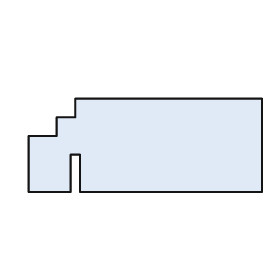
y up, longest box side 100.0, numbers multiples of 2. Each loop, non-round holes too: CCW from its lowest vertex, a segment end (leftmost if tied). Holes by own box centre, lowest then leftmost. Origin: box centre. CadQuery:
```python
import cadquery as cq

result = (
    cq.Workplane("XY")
    .moveTo(-50.0, -20.0)
    .lineTo(-32.0, -20.0)
    .lineTo(-32.0, -4.0)
    .lineTo(-28.0, -4.0)
    .lineTo(-28.0, -20.0)
    .lineTo(50.0, -20.0)
    .lineTo(50.0, 20.0)
    .lineTo(-30.0, 20.0)
    .lineTo(-30.0, 12.0)
    .lineTo(-38.0, 12.0)
    .lineTo(-38.0, 4.0)
    .lineTo(-50.0, 4.0)
    .close()
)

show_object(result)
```